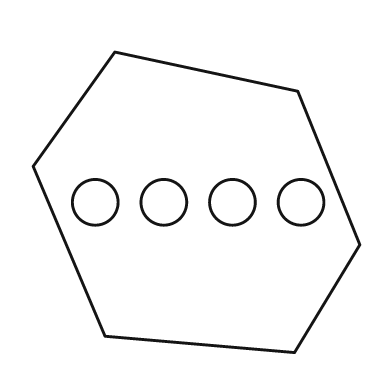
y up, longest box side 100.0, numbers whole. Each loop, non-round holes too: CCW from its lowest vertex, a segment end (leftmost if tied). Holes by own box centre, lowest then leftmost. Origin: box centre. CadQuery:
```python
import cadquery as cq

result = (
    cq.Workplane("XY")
    .moveTo(30.0, -46.0)
    .lineTo(50.0, -13.0)
    .lineTo(31.0, 34.0)
    .lineTo(-25.0, 46.0)
    .lineTo(-50.0, 11.0)
    .lineTo(-28.0, -41.0)
    .close()
    .moveTo(-31.0, 0.0)
    .circle(7.0)
    .moveTo(-10.0, 0.0)
    .circle(7.0)
    .moveTo(11.0, 0.0)
    .circle(7.0)
    .moveTo(32.0, 0.0)
    .circle(7.0)
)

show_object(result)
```